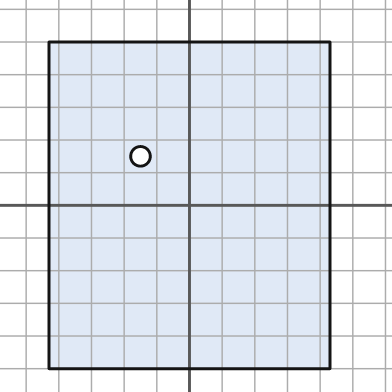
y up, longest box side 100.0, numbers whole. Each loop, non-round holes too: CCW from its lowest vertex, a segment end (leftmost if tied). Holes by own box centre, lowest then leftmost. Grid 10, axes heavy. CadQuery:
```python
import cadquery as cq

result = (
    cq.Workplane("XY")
    .moveTo(-43.0, -50.0)
    .lineTo(43.0, -50.0)
    .lineTo(43.0, 50.0)
    .lineTo(-43.0, 50.0)
    .close()
    .moveTo(-15.0, 15.0)
    .circle(3.0)
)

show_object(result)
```